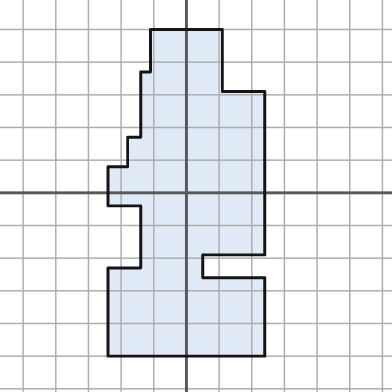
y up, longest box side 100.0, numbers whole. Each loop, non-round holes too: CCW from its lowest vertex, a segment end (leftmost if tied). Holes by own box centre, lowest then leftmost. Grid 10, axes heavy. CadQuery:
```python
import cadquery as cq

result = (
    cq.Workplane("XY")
    .moveTo(-24.0, -50.0)
    .lineTo(24.0, -50.0)
    .lineTo(24.0, -26.0)
    .lineTo(5.0, -26.0)
    .lineTo(5.0, -19.0)
    .lineTo(24.0, -19.0)
    .lineTo(24.0, 31.0)
    .lineTo(11.0, 31.0)
    .lineTo(11.0, 50.0)
    .lineTo(-11.0, 50.0)
    .lineTo(-11.0, 37.0)
    .lineTo(-14.0, 37.0)
    .lineTo(-14.0, 17.0)
    .lineTo(-18.0, 17.0)
    .lineTo(-18.0, 8.0)
    .lineTo(-24.0, 8.0)
    .lineTo(-24.0, -4.0)
    .lineTo(-14.0, -4.0)
    .lineTo(-14.0, -23.0)
    .lineTo(-24.0, -23.0)
    .close()
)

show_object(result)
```